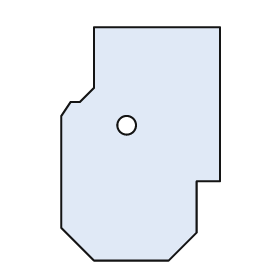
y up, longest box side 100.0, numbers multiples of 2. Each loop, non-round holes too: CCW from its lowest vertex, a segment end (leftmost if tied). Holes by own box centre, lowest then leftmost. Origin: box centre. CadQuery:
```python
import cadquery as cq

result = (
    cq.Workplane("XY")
    .moveTo(-20.0, -50.0)
    .lineTo(12.0, -50.0)
    .lineTo(24.0, -38.0)
    .lineTo(24.0, -16.0)
    .lineTo(34.0, -16.0)
    .lineTo(34.0, 50.0)
    .lineTo(-20.0, 50.0)
    .lineTo(-20.0, 24.0)
    .lineTo(-26.0, 18.0)
    .lineTo(-30.0, 18.0)
    .lineTo(-34.0, 12.0)
    .lineTo(-34.0, -36.0)
    .close()
    .moveTo(-6.0, 8.0)
    .circle(4.0)
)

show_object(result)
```